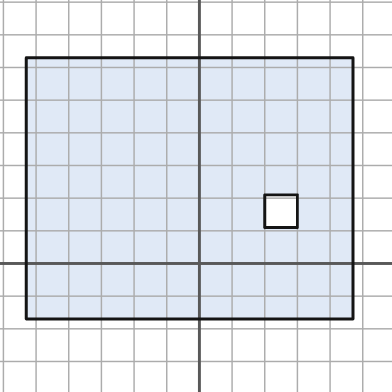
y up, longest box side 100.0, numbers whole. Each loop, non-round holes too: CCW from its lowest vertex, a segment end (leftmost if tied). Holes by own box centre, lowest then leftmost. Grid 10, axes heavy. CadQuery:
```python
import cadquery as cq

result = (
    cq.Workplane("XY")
    .moveTo(-53.0, -17.0)
    .lineTo(47.0, -17.0)
    .lineTo(47.0, 63.0)
    .lineTo(-53.0, 63.0)
    .close()
    .moveTo(20.0, 11.0)
    .lineTo(30.0, 11.0)
    .lineTo(30.0, 21.0)
    .lineTo(20.0, 21.0)
    .close()
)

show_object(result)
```